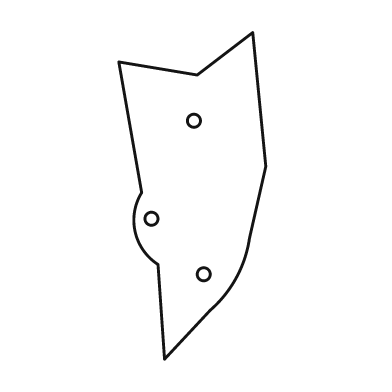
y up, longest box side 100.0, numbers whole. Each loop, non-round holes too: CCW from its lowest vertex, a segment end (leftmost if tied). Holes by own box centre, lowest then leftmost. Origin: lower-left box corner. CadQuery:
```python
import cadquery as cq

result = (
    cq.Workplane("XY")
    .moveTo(14.0, 0.0)
    .lineTo(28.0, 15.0)
    .threePointArc((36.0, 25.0), (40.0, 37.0))
    .lineTo(45.0, 59.0)
    .lineTo(41.0, 100.0)
    .lineTo(24.0, 87.0)
    .lineTo(0.0, 91.0)
    .lineTo(7.0, 51.0)
    .threePointArc((5.0, 39.0), (12.0, 29.0))
    .close()
    .moveTo(26.0, 26.0)
    .circle(2.0)
    .moveTo(10.0, 43.0)
    .circle(2.0)
    .moveTo(23.0, 73.0)
    .circle(2.0)
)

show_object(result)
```